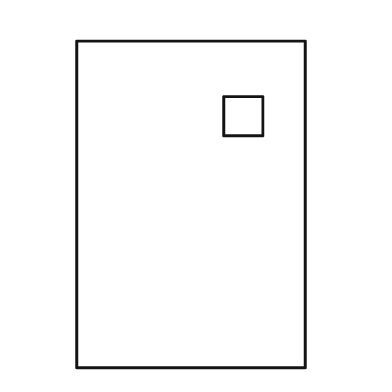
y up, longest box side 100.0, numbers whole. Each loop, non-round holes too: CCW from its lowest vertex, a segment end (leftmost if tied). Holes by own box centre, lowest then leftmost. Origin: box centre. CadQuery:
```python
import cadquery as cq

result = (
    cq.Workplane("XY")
    .moveTo(-35.0, -50.0)
    .lineTo(35.0, -50.0)
    .lineTo(35.0, 50.0)
    .lineTo(-35.0, 50.0)
    .close()
    .moveTo(10.0, 21.0)
    .lineTo(22.0, 21.0)
    .lineTo(22.0, 33.0)
    .lineTo(10.0, 33.0)
    .close()
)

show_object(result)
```